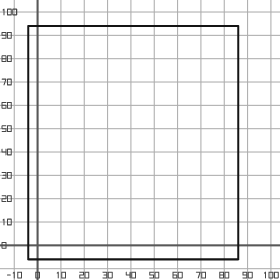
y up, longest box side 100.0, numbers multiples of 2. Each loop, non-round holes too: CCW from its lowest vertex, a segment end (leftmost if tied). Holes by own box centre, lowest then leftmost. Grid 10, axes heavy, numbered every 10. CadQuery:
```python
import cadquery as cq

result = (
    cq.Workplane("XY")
    .moveTo(-4.0, -6.0)
    .lineTo(86.0, -6.0)
    .lineTo(86.0, 94.0)
    .lineTo(-4.0, 94.0)
    .close()
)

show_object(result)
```